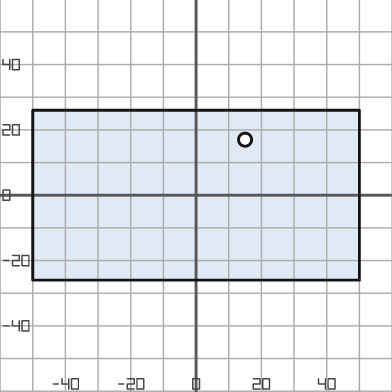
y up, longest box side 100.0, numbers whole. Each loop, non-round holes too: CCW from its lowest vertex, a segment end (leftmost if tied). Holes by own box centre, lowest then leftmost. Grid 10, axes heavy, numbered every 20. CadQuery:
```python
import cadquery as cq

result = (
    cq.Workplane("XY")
    .moveTo(-50.0, -26.0)
    .lineTo(50.0, -26.0)
    .lineTo(50.0, 26.0)
    .lineTo(-50.0, 26.0)
    .close()
    .moveTo(15.0, 17.0)
    .circle(2.0)
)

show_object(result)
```